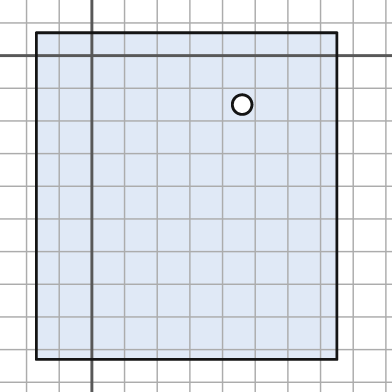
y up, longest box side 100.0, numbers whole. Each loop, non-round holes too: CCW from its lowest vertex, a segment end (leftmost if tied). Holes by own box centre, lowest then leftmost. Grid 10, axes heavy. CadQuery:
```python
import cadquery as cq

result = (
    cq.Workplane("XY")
    .moveTo(-17.0, -93.0)
    .lineTo(75.0, -93.0)
    .lineTo(75.0, 7.0)
    .lineTo(-17.0, 7.0)
    .close()
    .moveTo(46.0, -15.0)
    .circle(3.0)
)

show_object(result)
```